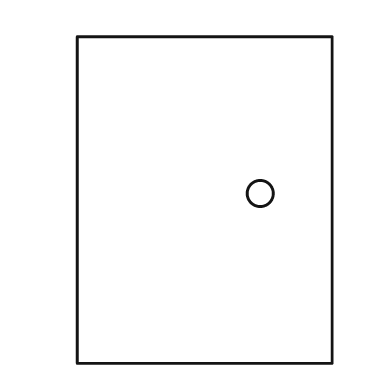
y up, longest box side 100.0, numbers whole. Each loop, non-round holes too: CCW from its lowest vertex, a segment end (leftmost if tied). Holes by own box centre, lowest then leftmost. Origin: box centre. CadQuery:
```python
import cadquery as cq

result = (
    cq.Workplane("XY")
    .moveTo(-39.0, -50.0)
    .lineTo(39.0, -50.0)
    .lineTo(39.0, 50.0)
    .lineTo(-39.0, 50.0)
    .close()
    .moveTo(17.0, 2.0)
    .circle(4.0)
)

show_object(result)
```